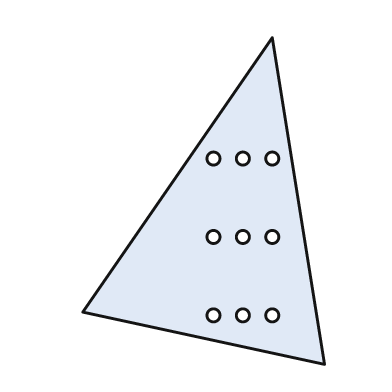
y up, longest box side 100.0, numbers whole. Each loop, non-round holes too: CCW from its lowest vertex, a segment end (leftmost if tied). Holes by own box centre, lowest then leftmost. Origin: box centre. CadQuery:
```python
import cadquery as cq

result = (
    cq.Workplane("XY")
    .moveTo(37.0, -50.0)
    .lineTo(21.0, 50.0)
    .lineTo(-37.0, -34.0)
    .close()
    .moveTo(3.0, -35.0)
    .circle(2.0)
    .moveTo(12.0, -35.0)
    .circle(2.0)
    .moveTo(21.0, -35.0)
    .circle(2.0)
    .moveTo(3.0, -11.0)
    .circle(2.0)
    .moveTo(12.0, -11.0)
    .circle(2.0)
    .moveTo(21.0, -11.0)
    .circle(2.0)
    .moveTo(3.0, 13.0)
    .circle(2.0)
    .moveTo(12.0, 13.0)
    .circle(2.0)
    .moveTo(21.0, 13.0)
    .circle(2.0)
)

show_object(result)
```